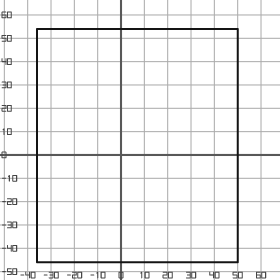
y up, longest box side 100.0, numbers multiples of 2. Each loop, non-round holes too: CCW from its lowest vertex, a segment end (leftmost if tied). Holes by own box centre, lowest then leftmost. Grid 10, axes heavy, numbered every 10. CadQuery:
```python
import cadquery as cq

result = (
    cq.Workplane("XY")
    .moveTo(-36.0, -46.0)
    .lineTo(50.0, -46.0)
    .lineTo(50.0, 54.0)
    .lineTo(-36.0, 54.0)
    .close()
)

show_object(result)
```